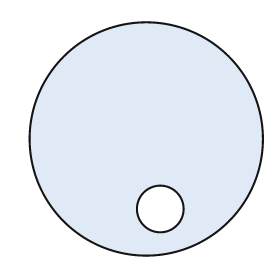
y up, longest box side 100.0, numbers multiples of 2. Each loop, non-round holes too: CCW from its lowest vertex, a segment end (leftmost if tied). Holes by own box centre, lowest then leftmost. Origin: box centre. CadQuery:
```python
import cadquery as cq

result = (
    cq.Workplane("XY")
    .moveTo(0.0, 0.0)
    .circle(50.0)
    .moveTo(6.0, -30.0)
    .circle(10.0)
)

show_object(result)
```